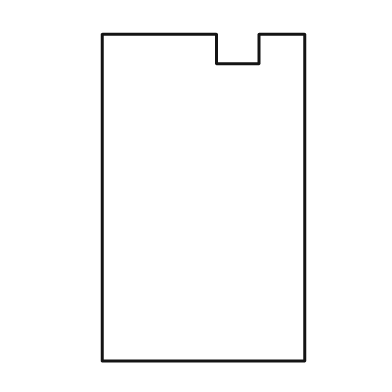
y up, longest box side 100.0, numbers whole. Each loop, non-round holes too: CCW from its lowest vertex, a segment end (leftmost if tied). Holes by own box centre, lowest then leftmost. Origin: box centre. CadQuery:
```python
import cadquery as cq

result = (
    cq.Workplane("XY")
    .moveTo(-31.0, -50.0)
    .lineTo(31.0, -50.0)
    .lineTo(31.0, 50.0)
    .lineTo(17.0, 50.0)
    .lineTo(17.0, 41.0)
    .lineTo(4.0, 41.0)
    .lineTo(4.0, 50.0)
    .lineTo(-31.0, 50.0)
    .close()
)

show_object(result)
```